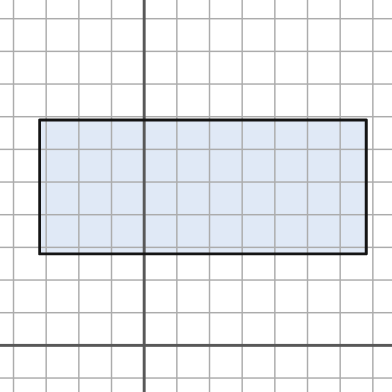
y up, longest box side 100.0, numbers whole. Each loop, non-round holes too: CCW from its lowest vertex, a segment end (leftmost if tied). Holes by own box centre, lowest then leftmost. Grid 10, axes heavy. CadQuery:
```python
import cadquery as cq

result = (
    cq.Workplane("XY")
    .moveTo(-32.0, 28.0)
    .lineTo(68.0, 28.0)
    .lineTo(68.0, 69.0)
    .lineTo(-32.0, 69.0)
    .close()
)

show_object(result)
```